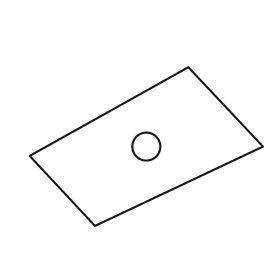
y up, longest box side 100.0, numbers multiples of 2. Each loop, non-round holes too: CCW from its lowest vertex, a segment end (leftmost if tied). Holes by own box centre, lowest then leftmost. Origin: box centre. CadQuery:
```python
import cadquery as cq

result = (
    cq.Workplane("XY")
    .moveTo(-22.0, -34.0)
    .lineTo(50.0, 0.0)
    .lineTo(18.0, 34.0)
    .lineTo(-50.0, -4.0)
    .close()
    .moveTo(0.0, 0.0)
    .circle(6.0)
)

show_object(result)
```